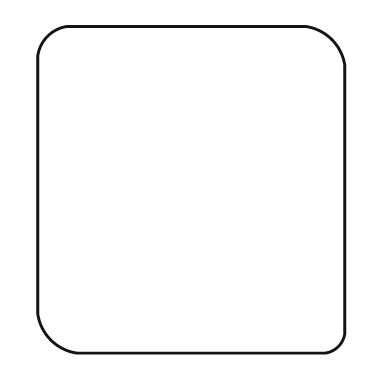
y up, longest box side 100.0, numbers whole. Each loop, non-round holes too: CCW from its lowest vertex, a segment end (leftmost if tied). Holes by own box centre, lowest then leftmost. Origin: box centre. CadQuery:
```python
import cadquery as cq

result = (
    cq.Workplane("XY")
    .moveTo(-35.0, -50.0)
    .lineTo(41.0, -50.0)
    .threePointArc((45.0, -48.0), (47.0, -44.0))
    .lineTo(47.0, 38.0)
    .threePointArc((43.0, 46.0), (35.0, 50.0))
    .lineTo(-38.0, 50.0)
    .threePointArc((-44.0, 47.0), (-47.0, 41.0))
    .lineTo(-47.0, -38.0)
    .threePointArc((-43.0, -46.0), (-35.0, -50.0))
    .close()
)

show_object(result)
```